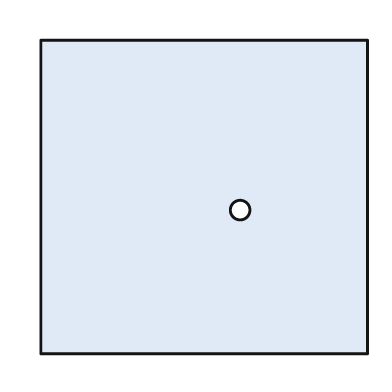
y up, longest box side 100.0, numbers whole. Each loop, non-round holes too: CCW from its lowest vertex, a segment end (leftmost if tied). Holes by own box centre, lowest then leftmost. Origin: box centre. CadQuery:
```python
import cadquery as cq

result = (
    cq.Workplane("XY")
    .moveTo(-50.0, -48.0)
    .lineTo(50.0, -48.0)
    .lineTo(50.0, 48.0)
    .lineTo(-50.0, 48.0)
    .close()
    .moveTo(11.0, -4.0)
    .circle(3.0)
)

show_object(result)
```